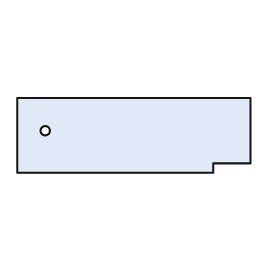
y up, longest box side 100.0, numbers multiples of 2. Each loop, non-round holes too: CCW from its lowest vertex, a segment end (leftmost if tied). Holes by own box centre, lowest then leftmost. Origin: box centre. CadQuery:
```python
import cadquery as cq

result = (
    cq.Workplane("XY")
    .moveTo(-50.0, -16.0)
    .lineTo(34.0, -16.0)
    .lineTo(34.0, -12.0)
    .lineTo(50.0, -12.0)
    .lineTo(50.0, 16.0)
    .lineTo(-50.0, 16.0)
    .close()
    .moveTo(-38.0, 2.0)
    .circle(2.0)
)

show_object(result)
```